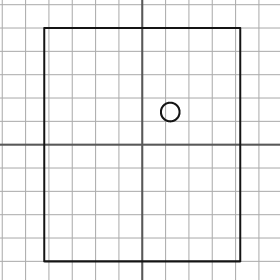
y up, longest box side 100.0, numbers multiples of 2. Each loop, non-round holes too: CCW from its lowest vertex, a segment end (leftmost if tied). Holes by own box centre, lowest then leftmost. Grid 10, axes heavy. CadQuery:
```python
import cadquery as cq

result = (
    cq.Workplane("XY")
    .moveTo(-42.0, -50.0)
    .lineTo(42.0, -50.0)
    .lineTo(42.0, 50.0)
    .lineTo(-42.0, 50.0)
    .close()
    .moveTo(12.0, 14.0)
    .circle(4.0)
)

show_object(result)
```